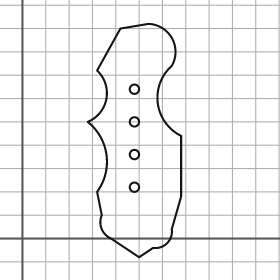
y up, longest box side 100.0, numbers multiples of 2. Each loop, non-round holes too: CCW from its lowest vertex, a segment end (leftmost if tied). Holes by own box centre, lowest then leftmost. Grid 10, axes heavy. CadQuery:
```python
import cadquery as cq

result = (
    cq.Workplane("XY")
    .moveTo(50.0, -8.0)
    .lineTo(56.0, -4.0)
    .threePointArc((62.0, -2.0), (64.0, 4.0))
    .lineTo(68.0, 18.0)
    .lineTo(68.0, 44.0)
    .threePointArc((58.0, 58.0), (64.0, 74.0))
    .threePointArc((64.0, 86.0), (54.0, 92.0))
    .lineTo(42.0, 90.0)
    .lineTo(32.0, 72.0)
    .threePointArc((36.0, 60.0), (28.0, 50.0))
    .threePointArc((36.0, 36.0), (32.0, 20.0))
    .lineTo(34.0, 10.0)
    .threePointArc((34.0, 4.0), (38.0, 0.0))
    .close()
    .moveTo(48.0, 22.0)
    .circle(2.0)
    .moveTo(48.0, 36.0)
    .circle(2.0)
    .moveTo(48.0, 50.0)
    .circle(2.0)
    .moveTo(48.0, 64.0)
    .circle(2.0)
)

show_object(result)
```